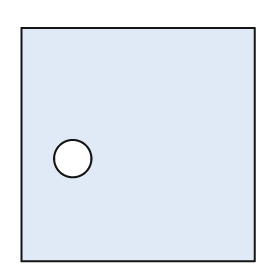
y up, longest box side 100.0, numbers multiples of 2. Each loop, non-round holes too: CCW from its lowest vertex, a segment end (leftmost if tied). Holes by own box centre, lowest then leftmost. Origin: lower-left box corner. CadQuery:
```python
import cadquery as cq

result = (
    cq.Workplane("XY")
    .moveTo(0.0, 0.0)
    .lineTo(100.0, 0.0)
    .lineTo(100.0, 100.0)
    .lineTo(0.0, 100.0)
    .close()
    .moveTo(22.0, 44.0)
    .circle(8.0)
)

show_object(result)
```